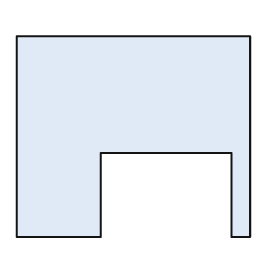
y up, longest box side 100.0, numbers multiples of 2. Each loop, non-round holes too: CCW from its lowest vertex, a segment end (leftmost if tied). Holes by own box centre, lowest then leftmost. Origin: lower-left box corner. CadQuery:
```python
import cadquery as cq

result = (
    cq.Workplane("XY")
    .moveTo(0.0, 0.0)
    .lineTo(36.0, 0.0)
    .lineTo(36.0, 36.0)
    .lineTo(92.0, 36.0)
    .lineTo(92.0, 0.0)
    .lineTo(100.0, 0.0)
    .lineTo(100.0, 86.0)
    .lineTo(0.0, 86.0)
    .close()
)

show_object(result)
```